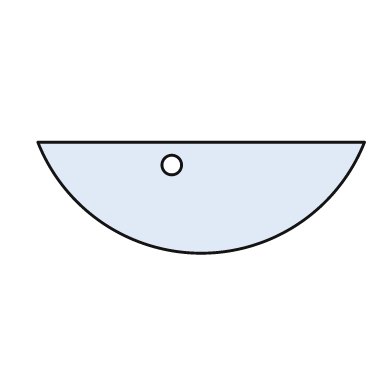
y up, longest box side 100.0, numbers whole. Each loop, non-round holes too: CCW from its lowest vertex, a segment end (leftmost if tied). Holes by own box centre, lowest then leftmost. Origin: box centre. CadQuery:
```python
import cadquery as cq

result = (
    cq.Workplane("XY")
    .moveTo(-50.0, 17.0)
    .threePointArc((0.0, -17.0), (50.0, 17.0))
    .close()
    .moveTo(-9.0, 10.0)
    .circle(3.0)
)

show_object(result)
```